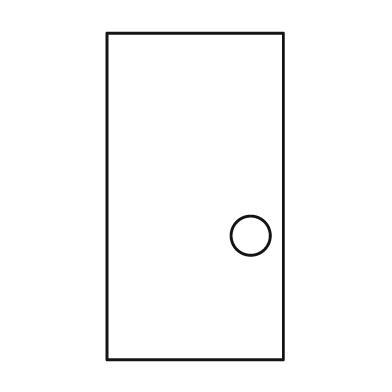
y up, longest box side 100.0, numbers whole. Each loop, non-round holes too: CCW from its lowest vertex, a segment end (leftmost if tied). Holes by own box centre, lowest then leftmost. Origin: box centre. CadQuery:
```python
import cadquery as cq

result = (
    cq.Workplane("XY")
    .moveTo(-27.0, -50.0)
    .lineTo(27.0, -50.0)
    .lineTo(27.0, 50.0)
    .lineTo(-27.0, 50.0)
    .close()
    .moveTo(17.0, -12.0)
    .circle(6.0)
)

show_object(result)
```